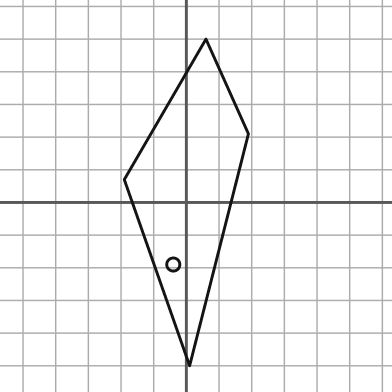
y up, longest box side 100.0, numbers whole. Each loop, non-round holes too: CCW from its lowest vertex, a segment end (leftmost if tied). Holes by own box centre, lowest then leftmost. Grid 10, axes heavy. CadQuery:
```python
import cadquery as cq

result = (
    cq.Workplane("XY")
    .moveTo(1.0, -50.0)
    .lineTo(19.0, 21.0)
    .lineTo(6.0, 50.0)
    .lineTo(-19.0, 7.0)
    .close()
    .moveTo(-4.0, -19.0)
    .circle(2.0)
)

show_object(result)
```